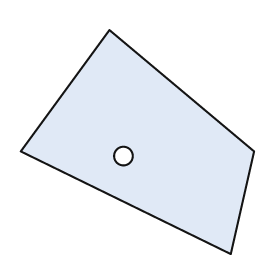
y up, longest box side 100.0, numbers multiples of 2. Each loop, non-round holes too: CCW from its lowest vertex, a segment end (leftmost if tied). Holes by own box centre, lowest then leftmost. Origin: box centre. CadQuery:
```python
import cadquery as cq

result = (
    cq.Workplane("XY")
    .moveTo(40.0, -48.0)
    .lineTo(50.0, -4.0)
    .lineTo(-12.0, 48.0)
    .lineTo(-50.0, -4.0)
    .close()
    .moveTo(-6.0, -6.0)
    .circle(4.0)
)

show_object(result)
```